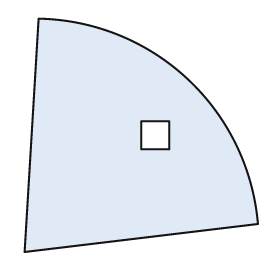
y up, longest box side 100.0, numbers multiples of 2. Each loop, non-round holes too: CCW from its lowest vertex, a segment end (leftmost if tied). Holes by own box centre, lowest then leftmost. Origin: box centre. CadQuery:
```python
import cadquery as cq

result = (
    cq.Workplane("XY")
    .moveTo(-50.0, -50.0)
    .lineTo(50.0, -38.0)
    .threePointArc((20.0, 24.0), (-44.0, 50.0))
    .close()
    .moveTo(0.0, -6.0)
    .lineTo(12.0, -6.0)
    .lineTo(12.0, 6.0)
    .lineTo(0.0, 6.0)
    .close()
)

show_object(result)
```